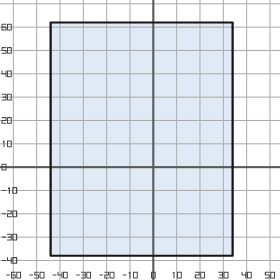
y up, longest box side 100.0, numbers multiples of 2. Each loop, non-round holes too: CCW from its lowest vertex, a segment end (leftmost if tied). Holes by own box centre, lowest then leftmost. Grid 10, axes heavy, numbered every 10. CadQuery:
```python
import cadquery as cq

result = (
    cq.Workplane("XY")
    .moveTo(-44.0, -38.0)
    .lineTo(34.0, -38.0)
    .lineTo(34.0, 62.0)
    .lineTo(-44.0, 62.0)
    .close()
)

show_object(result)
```